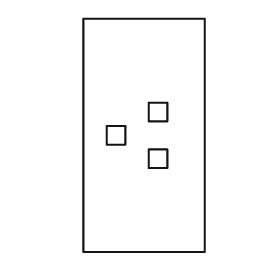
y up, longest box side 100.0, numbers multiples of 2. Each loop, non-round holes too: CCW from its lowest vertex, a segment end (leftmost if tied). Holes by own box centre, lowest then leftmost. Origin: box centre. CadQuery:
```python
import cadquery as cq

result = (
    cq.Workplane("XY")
    .moveTo(-26.0, -50.0)
    .lineTo(26.0, -50.0)
    .lineTo(26.0, 50.0)
    .lineTo(-26.0, 50.0)
    .close()
    .moveTo(2.0, -14.0)
    .lineTo(10.0, -14.0)
    .lineTo(10.0, -6.0)
    .lineTo(2.0, -6.0)
    .close()
    .moveTo(-16.0, -4.0)
    .lineTo(-8.0, -4.0)
    .lineTo(-8.0, 4.0)
    .lineTo(-16.0, 4.0)
    .close()
    .moveTo(2.0, 6.0)
    .lineTo(10.0, 6.0)
    .lineTo(10.0, 14.0)
    .lineTo(2.0, 14.0)
    .close()
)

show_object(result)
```